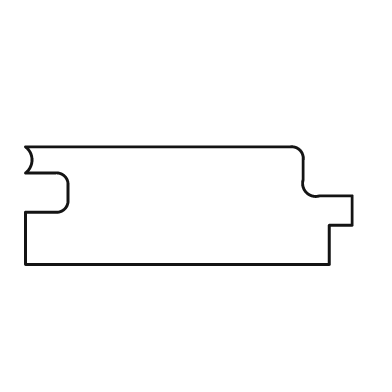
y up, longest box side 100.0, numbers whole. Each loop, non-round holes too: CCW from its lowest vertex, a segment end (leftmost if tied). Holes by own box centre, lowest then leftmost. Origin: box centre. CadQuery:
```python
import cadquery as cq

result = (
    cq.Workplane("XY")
    .moveTo(-50.0, -18.0)
    .lineTo(43.0, -18.0)
    .lineTo(43.0, -6.0)
    .lineTo(50.0, -6.0)
    .lineTo(50.0, 3.0)
    .lineTo(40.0, 3.0)
    .threePointArc((36.0, 4.0), (35.0, 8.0))
    .lineTo(35.0, 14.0)
    .threePointArc((34.0, 17.0), (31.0, 18.0))
    .lineTo(-50.0, 18.0)
    .threePointArc((-48.0, 14.0), (-50.0, 10.0))
    .lineTo(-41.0, 10.0)
    .threePointArc((-38.0, 9.0), (-37.0, 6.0))
    .lineTo(-37.0, 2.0)
    .threePointArc((-38.0, -1.0), (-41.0, -2.0))
    .lineTo(-50.0, -2.0)
    .close()
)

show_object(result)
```